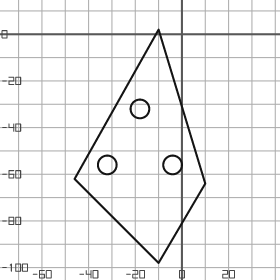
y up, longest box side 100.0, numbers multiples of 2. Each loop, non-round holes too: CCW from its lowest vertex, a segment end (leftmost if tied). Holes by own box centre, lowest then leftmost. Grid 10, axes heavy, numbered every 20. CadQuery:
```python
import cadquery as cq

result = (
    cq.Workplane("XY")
    .moveTo(-10.0, -98.0)
    .lineTo(10.0, -64.0)
    .lineTo(-10.0, 2.0)
    .lineTo(-46.0, -62.0)
    .close()
    .moveTo(-32.0, -56.0)
    .circle(4.0)
    .moveTo(-4.0, -56.0)
    .circle(4.0)
    .moveTo(-18.0, -32.0)
    .circle(4.0)
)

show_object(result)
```